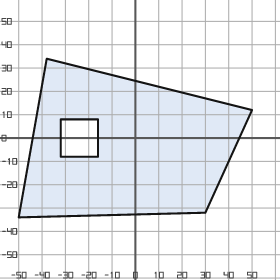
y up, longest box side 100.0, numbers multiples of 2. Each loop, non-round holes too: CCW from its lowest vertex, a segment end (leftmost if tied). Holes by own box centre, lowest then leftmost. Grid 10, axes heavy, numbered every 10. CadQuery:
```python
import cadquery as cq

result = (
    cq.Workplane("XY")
    .moveTo(-50.0, -34.0)
    .lineTo(30.0, -32.0)
    .lineTo(50.0, 12.0)
    .lineTo(-38.0, 34.0)
    .close()
    .moveTo(-32.0, -8.0)
    .lineTo(-16.0, -8.0)
    .lineTo(-16.0, 8.0)
    .lineTo(-32.0, 8.0)
    .close()
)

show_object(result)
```